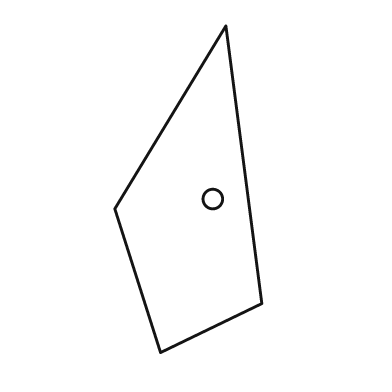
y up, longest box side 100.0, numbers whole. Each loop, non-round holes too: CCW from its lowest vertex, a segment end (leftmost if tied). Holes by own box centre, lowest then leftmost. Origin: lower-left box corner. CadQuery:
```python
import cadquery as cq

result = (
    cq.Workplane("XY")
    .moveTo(14.0, 0.0)
    .lineTo(45.0, 15.0)
    .lineTo(34.0, 100.0)
    .lineTo(0.0, 44.0)
    .close()
    .moveTo(30.0, 47.0)
    .circle(3.0)
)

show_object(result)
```